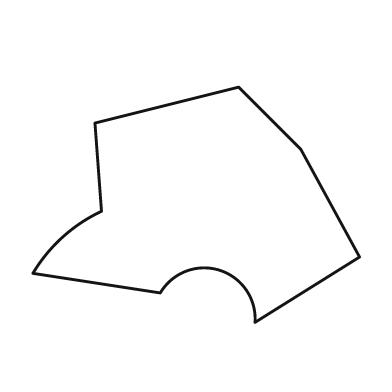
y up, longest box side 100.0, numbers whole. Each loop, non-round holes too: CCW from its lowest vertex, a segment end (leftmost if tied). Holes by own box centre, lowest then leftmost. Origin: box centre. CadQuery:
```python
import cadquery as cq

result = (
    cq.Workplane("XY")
    .moveTo(18.0, -36.0)
    .lineTo(50.0, -16.0)
    .lineTo(32.0, 17.0)
    .lineTo(13.0, 36.0)
    .lineTo(-31.0, 25.0)
    .lineTo(-29.0, -2.0)
    .threePointArc((-41.0, -10.0), (-50.0, -21.0))
    .lineTo(-11.0, -27.0)
    .threePointArc((7.0, -20.0), (18.0, -36.0))
    .close()
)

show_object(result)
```